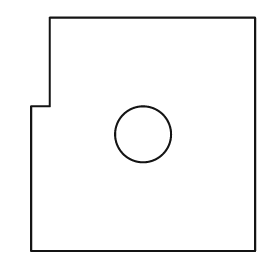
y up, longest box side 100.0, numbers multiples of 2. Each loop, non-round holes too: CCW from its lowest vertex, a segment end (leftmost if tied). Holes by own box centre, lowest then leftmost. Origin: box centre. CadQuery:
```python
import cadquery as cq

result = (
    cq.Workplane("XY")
    .moveTo(-48.0, -50.0)
    .lineTo(48.0, -50.0)
    .lineTo(48.0, 50.0)
    .lineTo(-40.0, 50.0)
    .lineTo(-40.0, 12.0)
    .lineTo(-48.0, 12.0)
    .close()
    .moveTo(0.0, 0.0)
    .circle(12.0)
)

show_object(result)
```